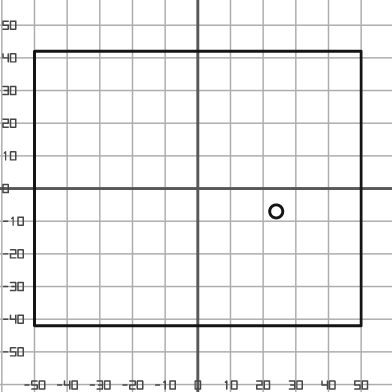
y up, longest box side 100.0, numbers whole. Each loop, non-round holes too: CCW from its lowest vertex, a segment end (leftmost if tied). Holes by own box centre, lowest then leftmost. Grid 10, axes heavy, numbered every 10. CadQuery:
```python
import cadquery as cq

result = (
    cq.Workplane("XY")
    .moveTo(-50.0, -42.0)
    .lineTo(50.0, -42.0)
    .lineTo(50.0, 42.0)
    .lineTo(-50.0, 42.0)
    .close()
    .moveTo(24.0, -7.0)
    .circle(2.0)
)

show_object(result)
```